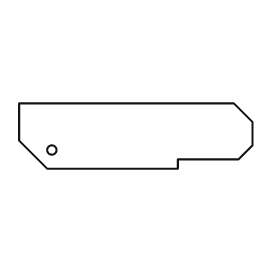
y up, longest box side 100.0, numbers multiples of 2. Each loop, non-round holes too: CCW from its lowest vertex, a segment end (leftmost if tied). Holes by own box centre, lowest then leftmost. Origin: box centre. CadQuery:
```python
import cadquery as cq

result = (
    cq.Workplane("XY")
    .moveTo(-38.0, -14.0)
    .lineTo(18.0, -14.0)
    .lineTo(18.0, -10.0)
    .lineTo(44.0, -10.0)
    .lineTo(50.0, -4.0)
    .lineTo(50.0, 6.0)
    .lineTo(42.0, 14.0)
    .lineTo(-50.0, 14.0)
    .lineTo(-50.0, -2.0)
    .close()
    .moveTo(-36.0, -6.0)
    .circle(2.0)
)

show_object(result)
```